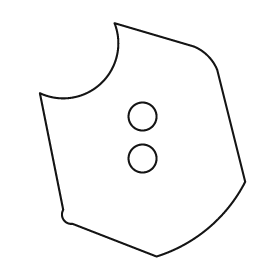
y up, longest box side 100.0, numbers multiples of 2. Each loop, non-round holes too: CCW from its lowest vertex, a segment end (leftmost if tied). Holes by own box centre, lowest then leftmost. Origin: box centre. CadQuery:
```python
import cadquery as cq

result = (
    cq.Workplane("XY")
    .moveTo(6.0, -50.0)
    .threePointArc((28.0, -38.0), (44.0, -18.0))
    .lineTo(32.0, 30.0)
    .threePointArc((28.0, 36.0), (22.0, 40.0))
    .lineTo(-12.0, 50.0)
    .threePointArc((-18.0, 24.0), (-44.0, 20.0))
    .lineTo(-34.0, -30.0)
    .threePointArc((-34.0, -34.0), (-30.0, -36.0))
    .close()
    .moveTo(0.0, -8.0)
    .circle(6.0)
    .moveTo(0.0, 10.0)
    .circle(6.0)
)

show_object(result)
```